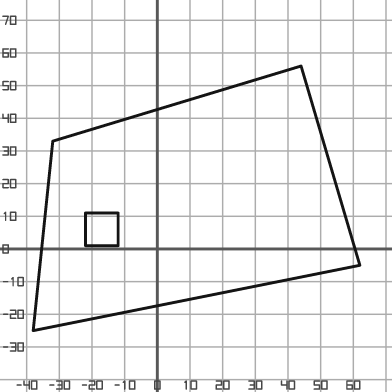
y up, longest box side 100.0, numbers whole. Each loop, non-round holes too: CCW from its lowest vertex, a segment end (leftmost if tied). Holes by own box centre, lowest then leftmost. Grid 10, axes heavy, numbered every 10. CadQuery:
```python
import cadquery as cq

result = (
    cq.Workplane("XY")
    .moveTo(-38.0, -25.0)
    .lineTo(62.0, -5.0)
    .lineTo(44.0, 56.0)
    .lineTo(-32.0, 33.0)
    .close()
    .moveTo(-22.0, 1.0)
    .lineTo(-12.0, 1.0)
    .lineTo(-12.0, 11.0)
    .lineTo(-22.0, 11.0)
    .close()
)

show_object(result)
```